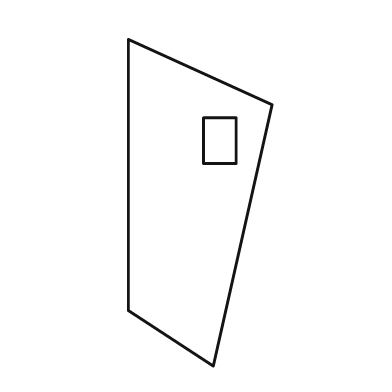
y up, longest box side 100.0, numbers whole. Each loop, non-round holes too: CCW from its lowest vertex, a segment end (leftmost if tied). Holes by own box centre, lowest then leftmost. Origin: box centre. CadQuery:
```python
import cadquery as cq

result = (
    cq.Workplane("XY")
    .moveTo(4.0, -50.0)
    .lineTo(22.0, 30.0)
    .lineTo(-22.0, 50.0)
    .lineTo(-22.0, -33.0)
    .close()
    .moveTo(1.0, 12.0)
    .lineTo(11.0, 12.0)
    .lineTo(11.0, 26.0)
    .lineTo(1.0, 26.0)
    .close()
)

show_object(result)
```